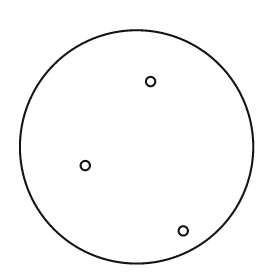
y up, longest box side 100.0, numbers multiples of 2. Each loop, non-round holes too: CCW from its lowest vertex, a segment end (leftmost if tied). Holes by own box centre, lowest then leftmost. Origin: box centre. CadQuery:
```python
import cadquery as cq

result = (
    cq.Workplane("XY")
    .moveTo(0.0, 0.0)
    .circle(50.0)
    .moveTo(20.0, -36.0)
    .circle(2.0)
    .moveTo(-22.0, -8.0)
    .circle(2.0)
    .moveTo(6.0, 28.0)
    .circle(2.0)
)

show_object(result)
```